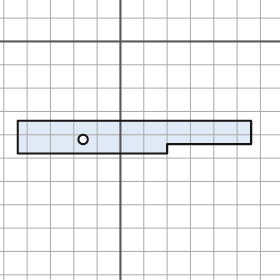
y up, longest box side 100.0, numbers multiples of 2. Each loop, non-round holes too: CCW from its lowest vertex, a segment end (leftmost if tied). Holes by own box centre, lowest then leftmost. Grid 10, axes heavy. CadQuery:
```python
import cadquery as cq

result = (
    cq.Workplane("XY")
    .moveTo(-44.0, -48.0)
    .lineTo(20.0, -48.0)
    .lineTo(20.0, -44.0)
    .lineTo(56.0, -44.0)
    .lineTo(56.0, -34.0)
    .lineTo(-44.0, -34.0)
    .close()
    .moveTo(-16.0, -42.0)
    .circle(2.0)
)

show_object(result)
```